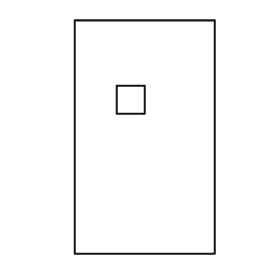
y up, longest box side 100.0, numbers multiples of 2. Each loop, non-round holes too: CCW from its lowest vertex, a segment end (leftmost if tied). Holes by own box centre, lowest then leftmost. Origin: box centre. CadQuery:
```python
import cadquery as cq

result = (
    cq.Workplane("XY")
    .moveTo(-30.0, -50.0)
    .lineTo(30.0, -50.0)
    .lineTo(30.0, 50.0)
    .lineTo(-30.0, 50.0)
    .close()
    .moveTo(-12.0, 10.0)
    .lineTo(0.0, 10.0)
    .lineTo(0.0, 22.0)
    .lineTo(-12.0, 22.0)
    .close()
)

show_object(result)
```